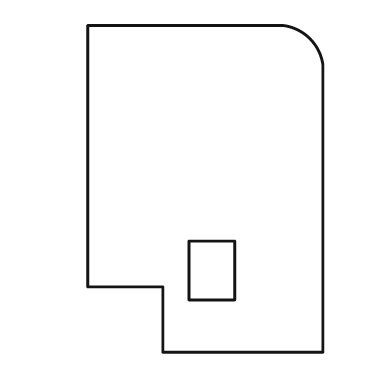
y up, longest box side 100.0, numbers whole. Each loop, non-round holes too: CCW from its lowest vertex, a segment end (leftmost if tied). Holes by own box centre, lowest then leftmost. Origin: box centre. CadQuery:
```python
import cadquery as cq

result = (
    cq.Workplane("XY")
    .moveTo(-13.0, -50.0)
    .lineTo(36.0, -50.0)
    .lineTo(36.0, 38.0)
    .threePointArc((32.0, 46.0), (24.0, 50.0))
    .lineTo(-36.0, 50.0)
    .lineTo(-36.0, -30.0)
    .lineTo(-13.0, -30.0)
    .close()
    .moveTo(-5.0, -34.0)
    .lineTo(9.0, -34.0)
    .lineTo(9.0, -16.0)
    .lineTo(-5.0, -16.0)
    .close()
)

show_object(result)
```